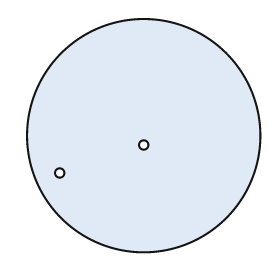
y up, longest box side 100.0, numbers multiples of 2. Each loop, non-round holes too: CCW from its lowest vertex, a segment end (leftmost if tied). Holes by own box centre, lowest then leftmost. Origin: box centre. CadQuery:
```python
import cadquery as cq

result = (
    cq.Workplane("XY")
    .moveTo(0.0, 0.0)
    .circle(50.0)
    .moveTo(-36.0, -16.0)
    .circle(2.0)
    .moveTo(0.0, -4.0)
    .circle(2.0)
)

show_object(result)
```